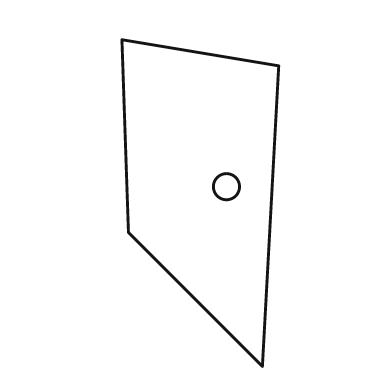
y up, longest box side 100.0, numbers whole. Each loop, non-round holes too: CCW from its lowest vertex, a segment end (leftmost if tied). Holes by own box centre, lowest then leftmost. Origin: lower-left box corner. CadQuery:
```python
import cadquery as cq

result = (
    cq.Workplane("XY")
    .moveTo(43.0, 0.0)
    .lineTo(48.0, 92.0)
    .lineTo(0.0, 100.0)
    .lineTo(2.0, 41.0)
    .close()
    .moveTo(32.0, 55.0)
    .circle(4.0)
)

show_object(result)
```